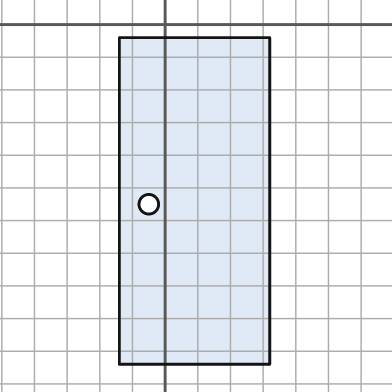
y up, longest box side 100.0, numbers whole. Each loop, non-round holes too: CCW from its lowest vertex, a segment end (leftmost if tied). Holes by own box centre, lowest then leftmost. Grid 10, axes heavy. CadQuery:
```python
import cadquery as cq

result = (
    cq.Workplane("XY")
    .moveTo(-14.0, -104.0)
    .lineTo(32.0, -104.0)
    .lineTo(32.0, -4.0)
    .lineTo(-14.0, -4.0)
    .close()
    .moveTo(-5.0, -55.0)
    .circle(3.0)
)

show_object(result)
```